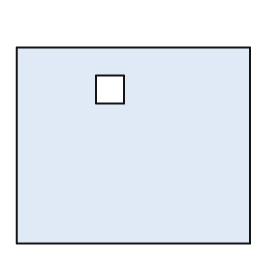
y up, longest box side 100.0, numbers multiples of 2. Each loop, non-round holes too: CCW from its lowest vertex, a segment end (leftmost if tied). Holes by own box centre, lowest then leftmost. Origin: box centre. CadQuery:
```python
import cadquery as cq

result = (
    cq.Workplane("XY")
    .moveTo(-50.0, -42.0)
    .lineTo(50.0, -42.0)
    .lineTo(50.0, 42.0)
    .lineTo(-50.0, 42.0)
    .close()
    .moveTo(-16.0, 18.0)
    .lineTo(-4.0, 18.0)
    .lineTo(-4.0, 30.0)
    .lineTo(-16.0, 30.0)
    .close()
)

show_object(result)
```